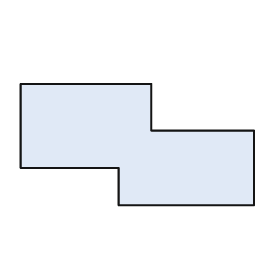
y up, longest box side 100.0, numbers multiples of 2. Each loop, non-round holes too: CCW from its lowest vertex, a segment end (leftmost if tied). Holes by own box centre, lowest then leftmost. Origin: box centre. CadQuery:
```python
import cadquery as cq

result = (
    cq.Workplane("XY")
    .moveTo(-8.0, -26.0)
    .lineTo(50.0, -26.0)
    .lineTo(50.0, 6.0)
    .lineTo(6.0, 6.0)
    .lineTo(6.0, 26.0)
    .lineTo(-50.0, 26.0)
    .lineTo(-50.0, -10.0)
    .lineTo(-8.0, -10.0)
    .close()
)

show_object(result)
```